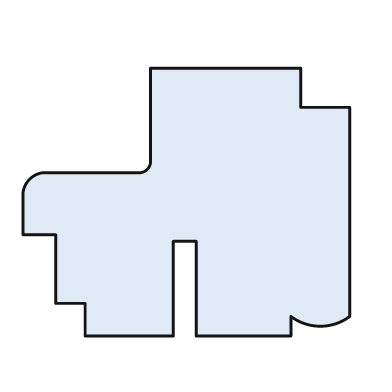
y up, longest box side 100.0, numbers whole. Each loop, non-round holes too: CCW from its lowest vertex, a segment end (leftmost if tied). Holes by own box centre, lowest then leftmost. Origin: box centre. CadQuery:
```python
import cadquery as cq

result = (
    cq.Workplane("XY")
    .moveTo(-31.0, -41.0)
    .lineTo(-4.0, -41.0)
    .lineTo(-4.0, -12.0)
    .lineTo(3.0, -12.0)
    .lineTo(3.0, -41.0)
    .lineTo(32.0, -41.0)
    .lineTo(32.0, -35.0)
    .threePointArc((41.0, -38.0), (50.0, -35.0))
    .lineTo(50.0, 29.0)
    .lineTo(35.0, 29.0)
    .lineTo(35.0, 41.0)
    .lineTo(-11.0, 41.0)
    .lineTo(-11.0, 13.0)
    .threePointArc((-12.0, 10.0), (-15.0, 9.0))
    .lineTo(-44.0, 9.0)
    .threePointArc((-48.0, 7.0), (-50.0, 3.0))
    .lineTo(-50.0, -10.0)
    .lineTo(-40.0, -10.0)
    .lineTo(-40.0, -31.0)
    .lineTo(-31.0, -31.0)
    .close()
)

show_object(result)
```